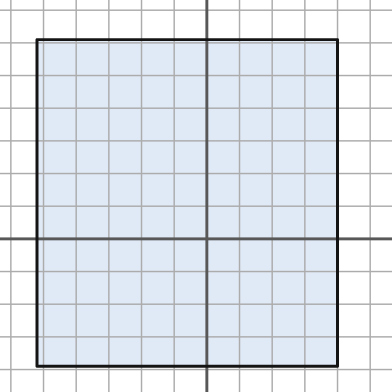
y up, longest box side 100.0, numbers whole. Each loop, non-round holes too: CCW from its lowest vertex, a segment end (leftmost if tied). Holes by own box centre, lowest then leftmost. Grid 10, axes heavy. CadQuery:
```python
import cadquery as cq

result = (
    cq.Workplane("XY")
    .moveTo(-52.0, -39.0)
    .lineTo(40.0, -39.0)
    .lineTo(40.0, 61.0)
    .lineTo(-52.0, 61.0)
    .close()
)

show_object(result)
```